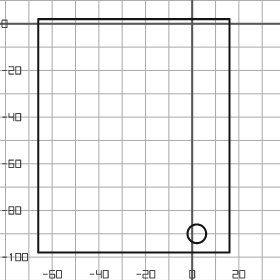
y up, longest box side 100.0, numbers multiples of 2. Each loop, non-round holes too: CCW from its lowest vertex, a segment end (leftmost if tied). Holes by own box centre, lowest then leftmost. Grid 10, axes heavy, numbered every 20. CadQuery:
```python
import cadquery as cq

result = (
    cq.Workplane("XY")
    .moveTo(-66.0, -98.0)
    .lineTo(16.0, -98.0)
    .lineTo(16.0, 2.0)
    .lineTo(-66.0, 2.0)
    .close()
    .moveTo(2.0, -90.0)
    .circle(4.0)
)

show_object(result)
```